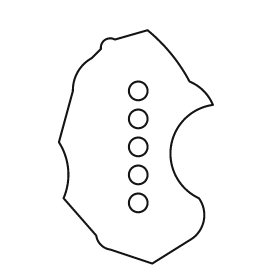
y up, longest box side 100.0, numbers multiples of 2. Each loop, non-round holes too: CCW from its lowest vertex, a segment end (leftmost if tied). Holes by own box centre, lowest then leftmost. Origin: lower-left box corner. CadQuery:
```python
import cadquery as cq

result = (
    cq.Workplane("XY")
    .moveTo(40.0, 0.0)
    .lineTo(56.0, 10.0)
    .threePointArc((62.0, 18.0), (60.0, 28.0))
    .threePointArc((48.0, 50.0), (66.0, 68.0))
    .threePointArc((62.0, 74.0), (56.0, 78.0))
    .threePointArc((48.0, 90.0), (38.0, 100.0))
    .lineTo(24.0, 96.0)
    .threePointArc((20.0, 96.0), (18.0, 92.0))
    .lineTo(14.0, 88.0)
    .threePointArc((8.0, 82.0), (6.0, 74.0))
    .lineTo(0.0, 52.0)
    .threePointArc((4.0, 40.0), (2.0, 28.0))
    .lineTo(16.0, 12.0)
    .threePointArc((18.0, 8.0), (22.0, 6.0))
    .close()
    .moveTo(34.0, 26.0)
    .circle(4.0)
    .moveTo(34.0, 38.0)
    .circle(4.0)
    .moveTo(34.0, 50.0)
    .circle(4.0)
    .moveTo(34.0, 62.0)
    .circle(4.0)
    .moveTo(34.0, 74.0)
    .circle(4.0)
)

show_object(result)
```